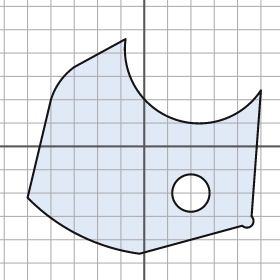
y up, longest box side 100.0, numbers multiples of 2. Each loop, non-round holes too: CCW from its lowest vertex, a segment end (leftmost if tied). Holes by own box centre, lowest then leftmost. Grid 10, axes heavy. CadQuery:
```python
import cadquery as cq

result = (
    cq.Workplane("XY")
    .moveTo(-2.0, -46.0)
    .lineTo(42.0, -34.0)
    .threePointArc((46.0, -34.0), (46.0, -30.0))
    .lineTo(50.0, 24.0)
    .threePointArc((12.0, 12.0), (-8.0, 46.0))
    .lineTo(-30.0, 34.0)
    .threePointArc((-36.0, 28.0), (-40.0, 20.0))
    .lineTo(-50.0, -22.0)
    .threePointArc((-28.0, -38.0), (-2.0, -46.0))
    .close()
    .moveTo(20.0, -20.0)
    .circle(8.0)
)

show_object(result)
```